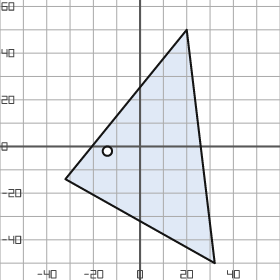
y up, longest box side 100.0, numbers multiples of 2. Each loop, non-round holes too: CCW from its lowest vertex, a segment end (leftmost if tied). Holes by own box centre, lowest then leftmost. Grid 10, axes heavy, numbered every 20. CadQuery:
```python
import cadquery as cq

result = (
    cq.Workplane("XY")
    .moveTo(32.0, -50.0)
    .lineTo(20.0, 50.0)
    .lineTo(-32.0, -14.0)
    .close()
    .moveTo(-14.0, -2.0)
    .circle(2.0)
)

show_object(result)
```